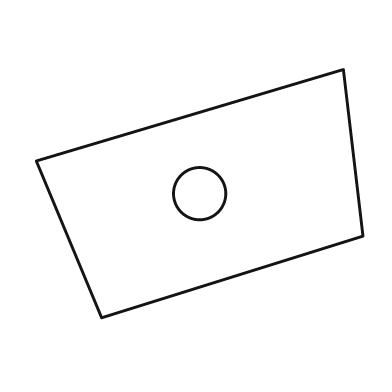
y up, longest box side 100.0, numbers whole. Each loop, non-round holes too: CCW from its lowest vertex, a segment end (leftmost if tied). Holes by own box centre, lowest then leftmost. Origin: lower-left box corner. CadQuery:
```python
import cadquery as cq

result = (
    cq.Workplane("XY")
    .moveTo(20.0, 0.0)
    .lineTo(100.0, 25.0)
    .lineTo(94.0, 76.0)
    .lineTo(0.0, 48.0)
    .close()
    .moveTo(50.0, 38.0)
    .circle(8.0)
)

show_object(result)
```